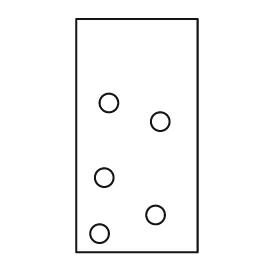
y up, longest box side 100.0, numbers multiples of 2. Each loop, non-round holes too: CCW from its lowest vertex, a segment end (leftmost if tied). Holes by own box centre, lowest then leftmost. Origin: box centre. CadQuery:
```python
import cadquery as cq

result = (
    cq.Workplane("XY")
    .moveTo(-26.0, -50.0)
    .lineTo(26.0, -50.0)
    .lineTo(26.0, 50.0)
    .lineTo(-26.0, 50.0)
    .close()
    .moveTo(-16.0, -42.0)
    .circle(4.0)
    .moveTo(8.0, -34.0)
    .circle(4.0)
    .moveTo(-14.0, -18.0)
    .circle(4.0)
    .moveTo(10.0, 6.0)
    .circle(4.0)
    .moveTo(-12.0, 14.0)
    .circle(4.0)
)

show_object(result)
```